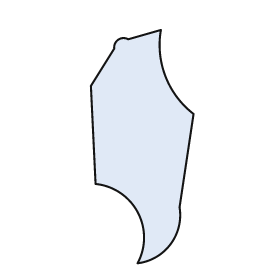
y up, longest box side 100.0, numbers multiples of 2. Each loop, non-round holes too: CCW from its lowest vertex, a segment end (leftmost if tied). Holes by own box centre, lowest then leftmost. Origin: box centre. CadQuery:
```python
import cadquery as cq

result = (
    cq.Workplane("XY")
    .moveTo(-2.0, -50.0)
    .threePointArc((12.0, -42.0), (16.0, -26.0))
    .lineTo(22.0, 14.0)
    .threePointArc((10.0, 30.0), (8.0, 50.0))
    .lineTo(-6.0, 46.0)
    .threePointArc((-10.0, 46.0), (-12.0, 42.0))
    .lineTo(-22.0, 26.0)
    .lineTo(-20.0, -16.0)
    .threePointArc((-2.0, -28.0), (-2.0, -50.0))
    .close()
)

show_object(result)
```